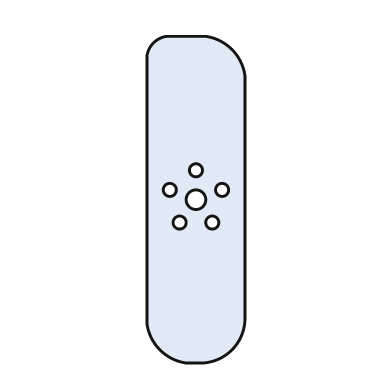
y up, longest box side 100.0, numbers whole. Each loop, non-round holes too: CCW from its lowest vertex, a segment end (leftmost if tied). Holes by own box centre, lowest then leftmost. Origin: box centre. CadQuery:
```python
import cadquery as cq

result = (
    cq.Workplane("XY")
    .moveTo(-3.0, -50.0)
    .lineTo(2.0, -50.0)
    .threePointArc((11.0, -46.0), (15.0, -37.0))
    .lineTo(15.0, 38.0)
    .threePointArc((11.0, 46.0), (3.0, 50.0))
    .lineTo(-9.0, 50.0)
    .threePointArc((-13.0, 48.0), (-15.0, 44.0))
    .lineTo(-15.0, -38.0)
    .threePointArc((-11.0, -46.0), (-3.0, -50.0))
    .close()
    .moveTo(-5.0, -7.0)
    .circle(2.0)
    .moveTo(5.0, -7.0)
    .circle(2.0)
    .moveTo(0.0, 0.0)
    .circle(3.0)
    .moveTo(-8.0, 3.0)
    .circle(2.0)
    .moveTo(8.0, 3.0)
    .circle(2.0)
    .moveTo(0.0, 9.0)
    .circle(2.0)
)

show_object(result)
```